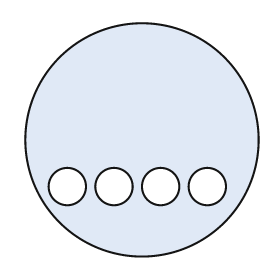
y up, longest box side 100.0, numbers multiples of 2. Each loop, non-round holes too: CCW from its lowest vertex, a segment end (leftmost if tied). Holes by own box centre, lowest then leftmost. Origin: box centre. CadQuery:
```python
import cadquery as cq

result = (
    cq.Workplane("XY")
    .moveTo(0.0, 0.0)
    .circle(50.0)
    .moveTo(-32.0, -20.0)
    .circle(8.0)
    .moveTo(-12.0, -20.0)
    .circle(8.0)
    .moveTo(8.0, -20.0)
    .circle(8.0)
    .moveTo(28.0, -20.0)
    .circle(8.0)
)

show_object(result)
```